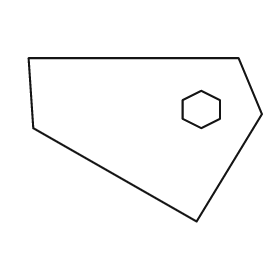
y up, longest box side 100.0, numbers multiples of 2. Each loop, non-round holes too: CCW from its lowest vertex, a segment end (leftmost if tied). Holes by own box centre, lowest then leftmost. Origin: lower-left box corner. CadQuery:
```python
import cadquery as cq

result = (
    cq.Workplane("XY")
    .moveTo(72.0, 0.0)
    .lineTo(100.0, 46.0)
    .lineTo(90.0, 70.0)
    .lineTo(0.0, 70.0)
    .lineTo(2.0, 40.0)
    .close()
    .moveTo(74.0, 40.0)
    .lineTo(82.0, 44.0)
    .lineTo(82.0, 52.0)
    .lineTo(74.0, 56.0)
    .lineTo(66.0, 52.0)
    .lineTo(66.0, 44.0)
    .close()
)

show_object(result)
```